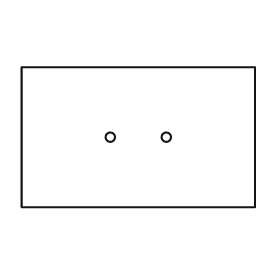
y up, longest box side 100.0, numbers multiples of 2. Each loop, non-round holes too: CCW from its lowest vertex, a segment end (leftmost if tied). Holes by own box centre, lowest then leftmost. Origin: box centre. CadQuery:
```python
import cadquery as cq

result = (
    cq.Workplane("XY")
    .moveTo(-50.0, -30.0)
    .lineTo(50.0, -30.0)
    .lineTo(50.0, 30.0)
    .lineTo(-50.0, 30.0)
    .close()
    .moveTo(-12.0, 0.0)
    .circle(2.0)
    .moveTo(12.0, 0.0)
    .circle(2.0)
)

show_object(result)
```